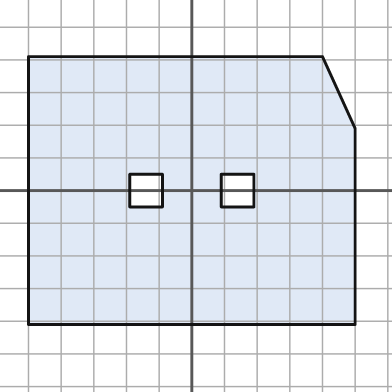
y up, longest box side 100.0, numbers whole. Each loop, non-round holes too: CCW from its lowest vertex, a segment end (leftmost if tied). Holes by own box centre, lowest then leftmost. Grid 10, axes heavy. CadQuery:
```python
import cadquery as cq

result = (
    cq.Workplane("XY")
    .moveTo(-50.0, -41.0)
    .lineTo(50.0, -41.0)
    .lineTo(50.0, 19.0)
    .lineTo(40.0, 41.0)
    .lineTo(-50.0, 41.0)
    .close()
    .moveTo(-19.0, -5.0)
    .lineTo(-9.0, -5.0)
    .lineTo(-9.0, 5.0)
    .lineTo(-19.0, 5.0)
    .close()
    .moveTo(9.0, -5.0)
    .lineTo(19.0, -5.0)
    .lineTo(19.0, 5.0)
    .lineTo(9.0, 5.0)
    .close()
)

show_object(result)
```